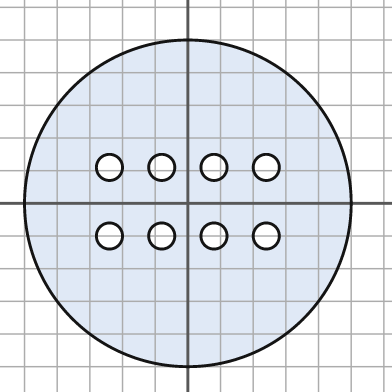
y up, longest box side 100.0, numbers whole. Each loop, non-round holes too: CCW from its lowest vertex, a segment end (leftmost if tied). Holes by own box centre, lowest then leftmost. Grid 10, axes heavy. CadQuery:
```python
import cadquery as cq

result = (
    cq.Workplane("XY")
    .moveTo(0.0, 0.0)
    .circle(50.0)
    .moveTo(-24.0, -10.0)
    .circle(4.0)
    .moveTo(-8.0, -10.0)
    .circle(4.0)
    .moveTo(8.0, -10.0)
    .circle(4.0)
    .moveTo(24.0, -10.0)
    .circle(4.0)
    .moveTo(-24.0, 11.0)
    .circle(4.0)
    .moveTo(-8.0, 11.0)
    .circle(4.0)
    .moveTo(8.0, 11.0)
    .circle(4.0)
    .moveTo(24.0, 11.0)
    .circle(4.0)
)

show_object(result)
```